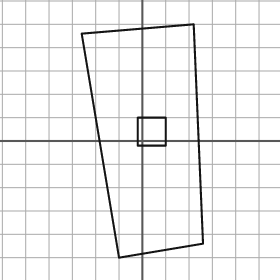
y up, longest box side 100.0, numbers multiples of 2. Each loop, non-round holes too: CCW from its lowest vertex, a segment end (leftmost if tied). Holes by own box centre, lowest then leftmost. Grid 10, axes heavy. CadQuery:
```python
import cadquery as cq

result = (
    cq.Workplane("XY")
    .moveTo(-10.0, -50.0)
    .lineTo(26.0, -44.0)
    .lineTo(22.0, 50.0)
    .lineTo(-26.0, 46.0)
    .close()
    .moveTo(-2.0, -2.0)
    .lineTo(10.0, -2.0)
    .lineTo(10.0, 10.0)
    .lineTo(-2.0, 10.0)
    .close()
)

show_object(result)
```